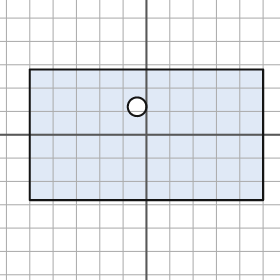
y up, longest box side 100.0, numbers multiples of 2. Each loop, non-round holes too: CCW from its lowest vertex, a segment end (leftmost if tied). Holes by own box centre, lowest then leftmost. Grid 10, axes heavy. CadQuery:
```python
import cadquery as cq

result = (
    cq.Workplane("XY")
    .moveTo(-50.0, -28.0)
    .lineTo(50.0, -28.0)
    .lineTo(50.0, 28.0)
    .lineTo(-50.0, 28.0)
    .close()
    .moveTo(-4.0, 12.0)
    .circle(4.0)
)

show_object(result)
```